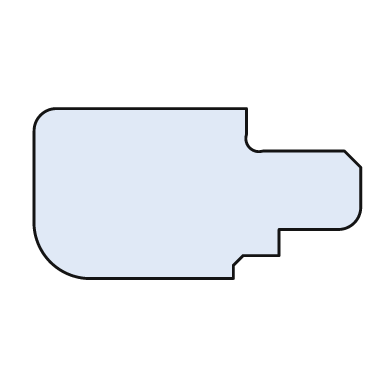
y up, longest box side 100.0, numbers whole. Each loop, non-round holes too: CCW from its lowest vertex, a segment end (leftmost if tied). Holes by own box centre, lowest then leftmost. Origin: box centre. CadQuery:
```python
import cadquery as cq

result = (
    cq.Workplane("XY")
    .moveTo(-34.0, -26.0)
    .lineTo(11.0, -26.0)
    .lineTo(11.0, -22.0)
    .lineTo(14.0, -19.0)
    .lineTo(25.0, -19.0)
    .lineTo(25.0, -11.0)
    .lineTo(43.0, -11.0)
    .threePointArc((48.0, -9.0), (50.0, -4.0))
    .lineTo(50.0, 8.0)
    .lineTo(45.0, 13.0)
    .lineTo(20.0, 13.0)
    .threePointArc((16.0, 14.0), (15.0, 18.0))
    .lineTo(15.0, 26.0)
    .lineTo(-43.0, 26.0)
    .threePointArc((-48.0, 24.0), (-50.0, 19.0))
    .lineTo(-50.0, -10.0)
    .threePointArc((-45.0, -21.0), (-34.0, -26.0))
    .close()
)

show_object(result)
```